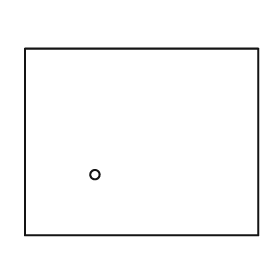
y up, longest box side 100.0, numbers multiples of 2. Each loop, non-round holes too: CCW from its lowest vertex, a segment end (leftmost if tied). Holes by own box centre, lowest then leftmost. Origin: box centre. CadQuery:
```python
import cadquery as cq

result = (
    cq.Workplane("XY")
    .moveTo(-50.0, -40.0)
    .lineTo(50.0, -40.0)
    .lineTo(50.0, 40.0)
    .lineTo(-50.0, 40.0)
    .close()
    .moveTo(-20.0, -14.0)
    .circle(2.0)
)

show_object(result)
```